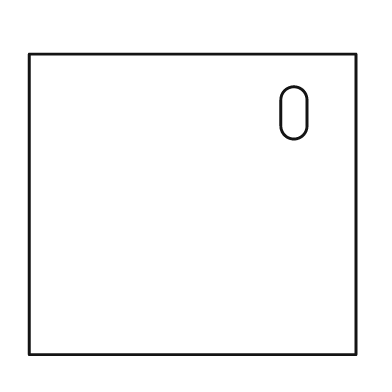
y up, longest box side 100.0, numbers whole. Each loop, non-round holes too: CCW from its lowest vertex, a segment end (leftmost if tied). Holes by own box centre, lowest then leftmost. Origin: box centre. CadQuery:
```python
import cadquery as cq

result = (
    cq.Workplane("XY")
    .moveTo(-50.0, -46.0)
    .lineTo(50.0, -46.0)
    .lineTo(50.0, 46.0)
    .lineTo(-50.0, 46.0)
    .close()
    .moveTo(27.0, 24.0)
    .threePointArc((31.0, 20.0), (35.0, 24.0))
    .lineTo(35.0, 32.0)
    .threePointArc((31.0, 36.0), (27.0, 32.0))
    .close()
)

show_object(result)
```